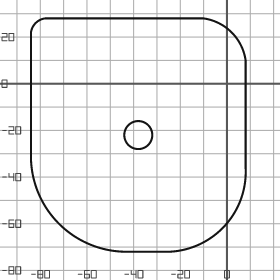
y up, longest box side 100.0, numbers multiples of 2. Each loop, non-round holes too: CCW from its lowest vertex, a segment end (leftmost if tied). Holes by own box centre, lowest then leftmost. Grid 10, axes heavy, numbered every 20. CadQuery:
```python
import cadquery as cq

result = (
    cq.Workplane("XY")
    .moveTo(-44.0, -72.0)
    .lineTo(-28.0, -72.0)
    .threePointArc((-2.0, -62.0), (8.0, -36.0))
    .lineTo(8.0, 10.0)
    .threePointArc((2.0, 22.0), (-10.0, 28.0))
    .lineTo(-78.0, 28.0)
    .threePointArc((-82.0, 26.0), (-84.0, 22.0))
    .lineTo(-84.0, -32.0)
    .threePointArc((-72.0, -60.0), (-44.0, -72.0))
    .close()
    .moveTo(-38.0, -22.0)
    .circle(6.0)
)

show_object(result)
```